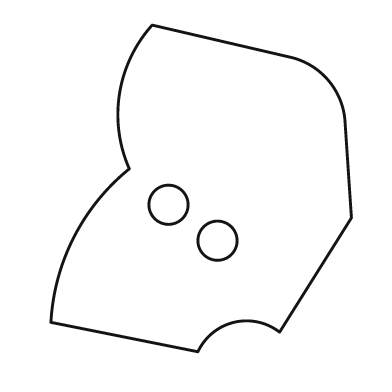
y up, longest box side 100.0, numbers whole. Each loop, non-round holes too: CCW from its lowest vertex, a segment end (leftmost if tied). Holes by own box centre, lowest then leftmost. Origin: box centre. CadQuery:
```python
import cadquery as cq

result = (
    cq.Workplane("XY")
    .moveTo(-1.0, -50.0)
    .threePointArc((10.0, -41.0), (24.0, -44.0))
    .lineTo(46.0, -9.0)
    .lineTo(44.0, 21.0)
    .threePointArc((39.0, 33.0), (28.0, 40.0))
    .lineTo(-15.0, 50.0)
    .threePointArc((-25.0, 29.0), (-22.0, 6.0))
    .threePointArc((-39.0, -15.0), (-46.0, -41.0))
    .close()
    .moveTo(5.0, -16.0)
    .circle(6.0)
    .moveTo(-10.0, -5.0)
    .circle(6.0)
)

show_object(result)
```